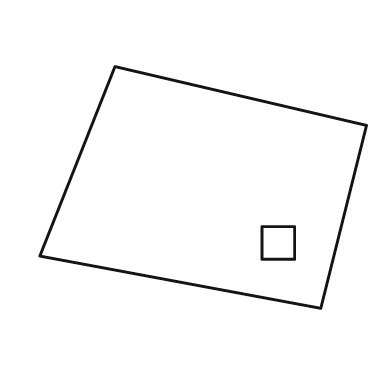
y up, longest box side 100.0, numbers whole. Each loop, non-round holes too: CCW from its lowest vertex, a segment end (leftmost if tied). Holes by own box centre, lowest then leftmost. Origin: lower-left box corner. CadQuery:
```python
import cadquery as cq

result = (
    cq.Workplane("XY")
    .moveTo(86.0, 0.0)
    .lineTo(100.0, 56.0)
    .lineTo(23.0, 74.0)
    .lineTo(0.0, 16.0)
    .close()
    .moveTo(68.0, 15.0)
    .lineTo(78.0, 15.0)
    .lineTo(78.0, 25.0)
    .lineTo(68.0, 25.0)
    .close()
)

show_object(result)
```